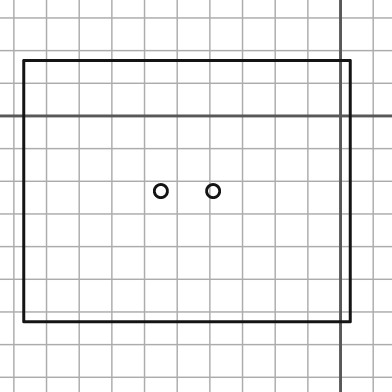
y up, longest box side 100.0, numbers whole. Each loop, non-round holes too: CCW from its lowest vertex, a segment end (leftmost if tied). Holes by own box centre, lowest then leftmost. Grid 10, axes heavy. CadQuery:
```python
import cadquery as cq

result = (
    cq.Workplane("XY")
    .moveTo(-97.0, -63.0)
    .lineTo(3.0, -63.0)
    .lineTo(3.0, 17.0)
    .lineTo(-97.0, 17.0)
    .close()
    .moveTo(-55.0, -23.0)
    .circle(2.0)
    .moveTo(-39.0, -23.0)
    .circle(2.0)
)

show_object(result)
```